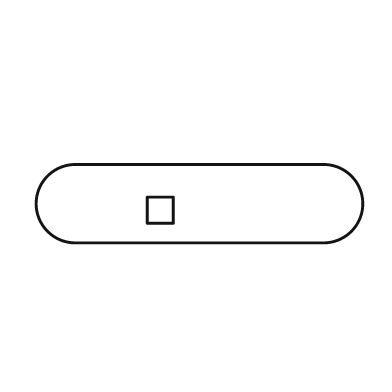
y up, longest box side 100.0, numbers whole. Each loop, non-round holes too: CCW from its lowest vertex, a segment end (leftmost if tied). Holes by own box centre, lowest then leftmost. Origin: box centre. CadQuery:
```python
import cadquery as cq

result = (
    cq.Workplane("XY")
    .moveTo(-38.0, -12.0)
    .lineTo(38.0, -12.0)
    .threePointArc((50.0, 0.0), (38.0, 12.0))
    .lineTo(-38.0, 12.0)
    .threePointArc((-50.0, 0.0), (-38.0, -12.0))
    .close()
    .moveTo(-16.0, -6.0)
    .lineTo(-8.0, -6.0)
    .lineTo(-8.0, 2.0)
    .lineTo(-16.0, 2.0)
    .close()
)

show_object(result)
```